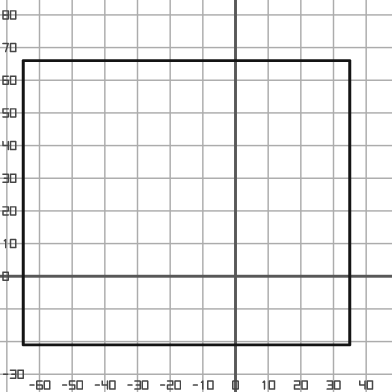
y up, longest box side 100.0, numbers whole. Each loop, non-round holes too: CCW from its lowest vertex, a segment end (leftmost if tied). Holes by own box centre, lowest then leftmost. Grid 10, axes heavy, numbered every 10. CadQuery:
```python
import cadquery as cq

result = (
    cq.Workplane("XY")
    .moveTo(-65.0, -21.0)
    .lineTo(35.0, -21.0)
    .lineTo(35.0, 66.0)
    .lineTo(-65.0, 66.0)
    .close()
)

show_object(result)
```